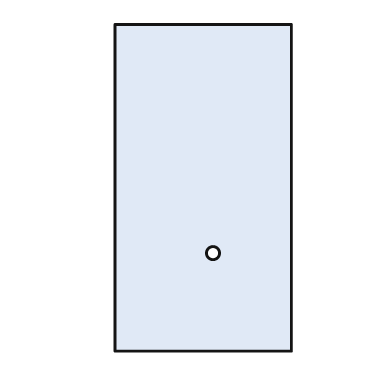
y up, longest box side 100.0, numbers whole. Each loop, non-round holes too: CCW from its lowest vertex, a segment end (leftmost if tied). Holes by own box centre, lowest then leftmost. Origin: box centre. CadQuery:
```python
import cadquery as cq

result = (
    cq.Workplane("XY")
    .moveTo(-27.0, -50.0)
    .lineTo(27.0, -50.0)
    .lineTo(27.0, 50.0)
    .lineTo(-27.0, 50.0)
    .close()
    .moveTo(3.0, -20.0)
    .circle(2.0)
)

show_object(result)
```